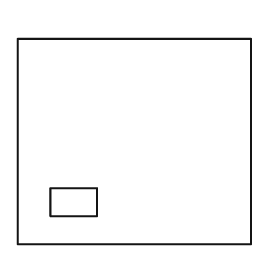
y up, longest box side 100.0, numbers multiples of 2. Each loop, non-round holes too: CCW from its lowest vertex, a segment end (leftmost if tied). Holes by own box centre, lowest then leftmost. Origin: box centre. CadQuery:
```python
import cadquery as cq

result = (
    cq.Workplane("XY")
    .moveTo(-50.0, -44.0)
    .lineTo(50.0, -44.0)
    .lineTo(50.0, 44.0)
    .lineTo(-50.0, 44.0)
    .close()
    .moveTo(-36.0, -32.0)
    .lineTo(-16.0, -32.0)
    .lineTo(-16.0, -20.0)
    .lineTo(-36.0, -20.0)
    .close()
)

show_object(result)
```